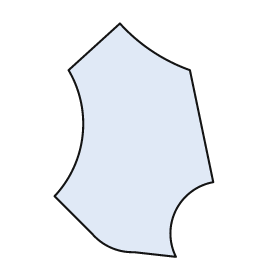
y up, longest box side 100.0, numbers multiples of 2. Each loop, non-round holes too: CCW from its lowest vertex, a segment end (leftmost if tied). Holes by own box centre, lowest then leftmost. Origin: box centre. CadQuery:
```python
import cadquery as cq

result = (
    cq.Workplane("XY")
    .moveTo(18.0, -50.0)
    .threePointArc((18.0, -30.0), (34.0, -18.0))
    .lineTo(24.0, 30.0)
    .threePointArc((8.0, 38.0), (-6.0, 50.0))
    .lineTo(-28.0, 30.0)
    .threePointArc((-22.0, 2.0), (-34.0, -24.0))
    .lineTo(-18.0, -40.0)
    .threePointArc((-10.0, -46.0), (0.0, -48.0))
    .close()
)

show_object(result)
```